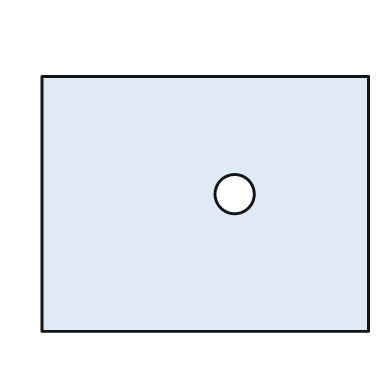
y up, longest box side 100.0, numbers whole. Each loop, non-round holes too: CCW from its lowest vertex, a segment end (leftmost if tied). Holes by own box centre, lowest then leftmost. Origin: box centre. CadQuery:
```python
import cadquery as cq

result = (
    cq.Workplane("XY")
    .moveTo(-50.0, -39.0)
    .lineTo(50.0, -39.0)
    .lineTo(50.0, 39.0)
    .lineTo(-50.0, 39.0)
    .close()
    .moveTo(9.0, 3.0)
    .circle(6.0)
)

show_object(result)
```